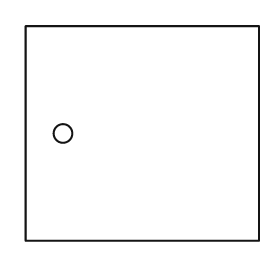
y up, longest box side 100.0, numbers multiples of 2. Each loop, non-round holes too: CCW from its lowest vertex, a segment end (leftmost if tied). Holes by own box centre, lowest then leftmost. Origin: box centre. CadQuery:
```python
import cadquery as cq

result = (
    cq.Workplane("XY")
    .moveTo(-50.0, -46.0)
    .lineTo(50.0, -46.0)
    .lineTo(50.0, 46.0)
    .lineTo(-50.0, 46.0)
    .close()
    .moveTo(-34.0, 0.0)
    .circle(4.0)
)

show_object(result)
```